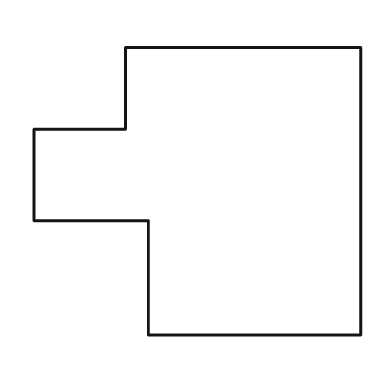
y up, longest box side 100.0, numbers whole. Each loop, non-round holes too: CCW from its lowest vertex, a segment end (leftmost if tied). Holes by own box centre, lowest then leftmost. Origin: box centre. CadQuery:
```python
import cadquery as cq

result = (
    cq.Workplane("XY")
    .moveTo(-15.0, -44.0)
    .lineTo(50.0, -44.0)
    .lineTo(50.0, 44.0)
    .lineTo(-22.0, 44.0)
    .lineTo(-22.0, 19.0)
    .lineTo(-50.0, 19.0)
    .lineTo(-50.0, -9.0)
    .lineTo(-15.0, -9.0)
    .close()
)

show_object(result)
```